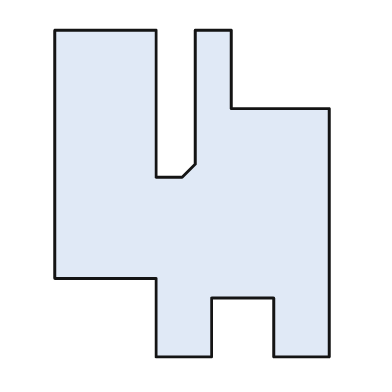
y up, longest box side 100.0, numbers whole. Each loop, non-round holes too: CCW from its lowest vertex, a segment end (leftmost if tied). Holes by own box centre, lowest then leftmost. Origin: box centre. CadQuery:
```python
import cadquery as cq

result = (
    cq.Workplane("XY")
    .moveTo(-11.0, -50.0)
    .lineTo(6.0, -50.0)
    .lineTo(6.0, -32.0)
    .lineTo(25.0, -32.0)
    .lineTo(25.0, -50.0)
    .lineTo(42.0, -50.0)
    .lineTo(42.0, 26.0)
    .lineTo(12.0, 26.0)
    .lineTo(12.0, 50.0)
    .lineTo(1.0, 50.0)
    .lineTo(1.0, 9.0)
    .lineTo(-3.0, 5.0)
    .lineTo(-11.0, 5.0)
    .lineTo(-11.0, 50.0)
    .lineTo(-42.0, 50.0)
    .lineTo(-42.0, -26.0)
    .lineTo(-11.0, -26.0)
    .close()
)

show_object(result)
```